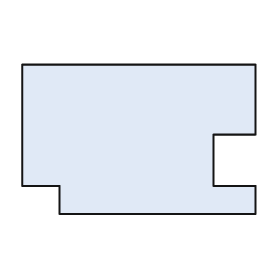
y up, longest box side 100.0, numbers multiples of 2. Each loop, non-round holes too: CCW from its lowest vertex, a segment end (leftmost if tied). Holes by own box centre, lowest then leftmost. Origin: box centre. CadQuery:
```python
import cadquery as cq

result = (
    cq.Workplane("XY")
    .moveTo(-34.0, -32.0)
    .lineTo(50.0, -32.0)
    .lineTo(50.0, -20.0)
    .lineTo(32.0, -20.0)
    .lineTo(32.0, 2.0)
    .lineTo(50.0, 2.0)
    .lineTo(50.0, 32.0)
    .lineTo(-50.0, 32.0)
    .lineTo(-50.0, -20.0)
    .lineTo(-34.0, -20.0)
    .close()
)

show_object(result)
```